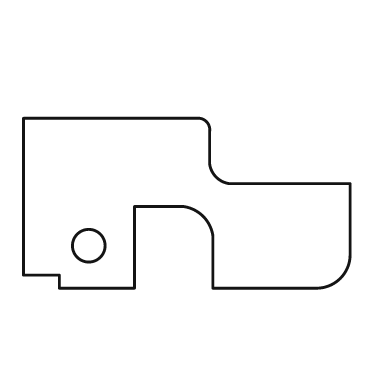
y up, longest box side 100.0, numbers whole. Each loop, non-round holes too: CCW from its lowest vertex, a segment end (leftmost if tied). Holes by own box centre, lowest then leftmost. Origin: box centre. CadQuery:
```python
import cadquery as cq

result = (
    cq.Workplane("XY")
    .moveTo(-39.0, -26.0)
    .lineTo(-16.0, -26.0)
    .lineTo(-16.0, -1.0)
    .lineTo(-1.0, -1.0)
    .threePointArc((5.0, -4.0), (8.0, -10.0))
    .lineTo(8.0, -26.0)
    .lineTo(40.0, -26.0)
    .threePointArc((47.0, -23.0), (50.0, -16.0))
    .lineTo(50.0, 6.0)
    .lineTo(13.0, 6.0)
    .threePointArc((9.0, 8.0), (7.0, 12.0))
    .lineTo(7.0, 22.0)
    .threePointArc((6.0, 25.0), (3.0, 26.0))
    .lineTo(-50.0, 26.0)
    .lineTo(-50.0, -22.0)
    .lineTo(-39.0, -22.0)
    .close()
    .moveTo(-30.0, -13.0)
    .circle(5.0)
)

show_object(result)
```